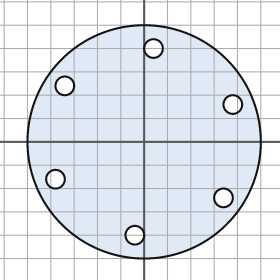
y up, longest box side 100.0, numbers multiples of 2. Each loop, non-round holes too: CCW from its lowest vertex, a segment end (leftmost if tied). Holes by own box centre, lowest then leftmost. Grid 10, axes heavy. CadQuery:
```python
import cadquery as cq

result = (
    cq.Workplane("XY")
    .moveTo(0.0, 0.0)
    .circle(50.0)
    .moveTo(-4.0, -40.0)
    .circle(4.0)
    .moveTo(34.0, -24.0)
    .circle(4.0)
    .moveTo(-38.0, -16.0)
    .circle(4.0)
    .moveTo(38.0, 16.0)
    .circle(4.0)
    .moveTo(-34.0, 24.0)
    .circle(4.0)
    .moveTo(4.0, 40.0)
    .circle(4.0)
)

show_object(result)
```